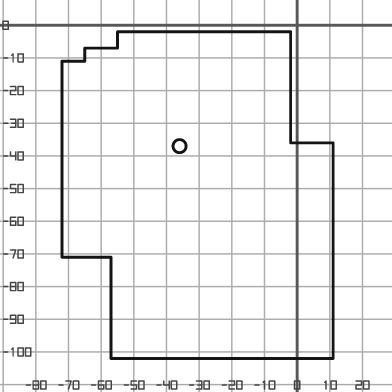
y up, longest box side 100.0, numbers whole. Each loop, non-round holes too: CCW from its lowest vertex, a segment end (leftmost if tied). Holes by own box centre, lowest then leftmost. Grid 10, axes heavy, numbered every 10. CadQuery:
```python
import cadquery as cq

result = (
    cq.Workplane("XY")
    .moveTo(-57.0, -102.0)
    .lineTo(11.0, -102.0)
    .lineTo(11.0, -36.0)
    .lineTo(-2.0, -36.0)
    .lineTo(-2.0, -2.0)
    .lineTo(-55.0, -2.0)
    .lineTo(-55.0, -7.0)
    .lineTo(-65.0, -7.0)
    .lineTo(-65.0, -11.0)
    .lineTo(-72.0, -11.0)
    .lineTo(-72.0, -71.0)
    .lineTo(-57.0, -71.0)
    .close()
    .moveTo(-36.0, -37.0)
    .circle(2.0)
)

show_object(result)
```